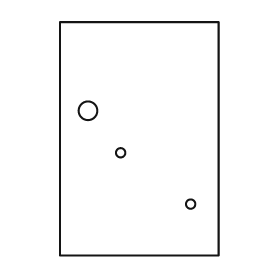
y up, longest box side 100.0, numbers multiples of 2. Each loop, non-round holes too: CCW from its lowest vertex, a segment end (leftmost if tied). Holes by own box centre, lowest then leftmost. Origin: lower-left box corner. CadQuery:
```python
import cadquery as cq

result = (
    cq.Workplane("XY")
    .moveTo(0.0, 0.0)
    .lineTo(68.0, 0.0)
    .lineTo(68.0, 100.0)
    .lineTo(0.0, 100.0)
    .close()
    .moveTo(56.0, 22.0)
    .circle(2.0)
    .moveTo(26.0, 44.0)
    .circle(2.0)
    .moveTo(12.0, 62.0)
    .circle(4.0)
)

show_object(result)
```